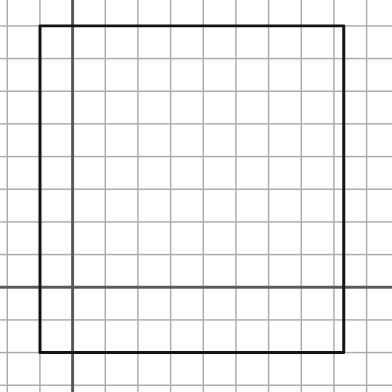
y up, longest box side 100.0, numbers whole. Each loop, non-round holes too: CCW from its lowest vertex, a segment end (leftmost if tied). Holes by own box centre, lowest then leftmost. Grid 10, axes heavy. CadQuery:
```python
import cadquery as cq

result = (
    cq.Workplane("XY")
    .moveTo(-10.0, -20.0)
    .lineTo(83.0, -20.0)
    .lineTo(83.0, 80.0)
    .lineTo(-10.0, 80.0)
    .close()
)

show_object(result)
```